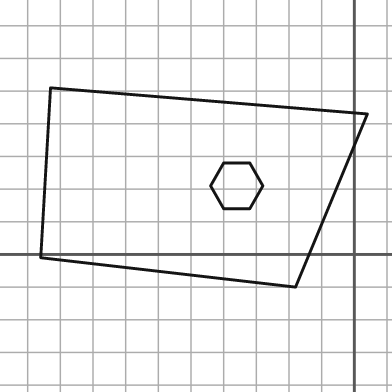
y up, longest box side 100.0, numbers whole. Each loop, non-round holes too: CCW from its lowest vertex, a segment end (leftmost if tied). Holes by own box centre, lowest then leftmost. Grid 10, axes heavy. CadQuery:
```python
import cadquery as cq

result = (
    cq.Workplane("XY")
    .moveTo(-18.0, -10.0)
    .lineTo(4.0, 43.0)
    .lineTo(-93.0, 51.0)
    .lineTo(-96.0, -1.0)
    .close()
    .moveTo(-40.0, 14.0)
    .lineTo(-32.0, 14.0)
    .lineTo(-28.0, 21.0)
    .lineTo(-32.0, 28.0)
    .lineTo(-40.0, 28.0)
    .lineTo(-44.0, 21.0)
    .close()
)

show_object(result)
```